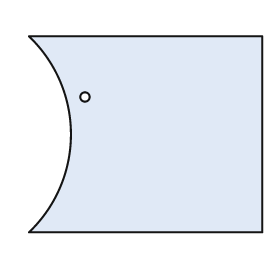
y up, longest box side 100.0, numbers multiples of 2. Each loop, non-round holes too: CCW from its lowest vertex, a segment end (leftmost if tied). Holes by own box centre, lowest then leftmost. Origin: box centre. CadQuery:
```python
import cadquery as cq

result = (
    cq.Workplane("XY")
    .moveTo(-50.0, -42.0)
    .lineTo(50.0, -42.0)
    .lineTo(50.0, 42.0)
    .lineTo(-50.0, 42.0)
    .threePointArc((-32.0, 0.0), (-50.0, -42.0))
    .close()
    .moveTo(-26.0, 16.0)
    .circle(2.0)
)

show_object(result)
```